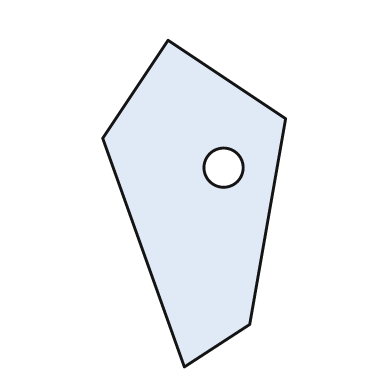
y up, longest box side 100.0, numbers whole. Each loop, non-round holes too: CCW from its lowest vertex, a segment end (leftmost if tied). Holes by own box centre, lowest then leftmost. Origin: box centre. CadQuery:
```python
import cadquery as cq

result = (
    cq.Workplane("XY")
    .moveTo(-3.0, -50.0)
    .lineTo(17.0, -37.0)
    .lineTo(28.0, 26.0)
    .lineTo(-8.0, 50.0)
    .lineTo(-28.0, 20.0)
    .close()
    .moveTo(9.0, 11.0)
    .circle(6.0)
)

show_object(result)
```